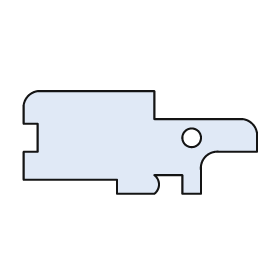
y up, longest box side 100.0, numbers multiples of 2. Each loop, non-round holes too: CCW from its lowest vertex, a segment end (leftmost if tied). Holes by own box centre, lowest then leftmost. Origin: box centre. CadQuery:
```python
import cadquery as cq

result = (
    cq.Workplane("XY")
    .moveTo(-10.0, -22.0)
    .lineTo(6.0, -22.0)
    .threePointArc((8.0, -18.0), (6.0, -14.0))
    .lineTo(18.0, -14.0)
    .lineTo(18.0, -22.0)
    .lineTo(26.0, -22.0)
    .lineTo(26.0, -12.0)
    .threePointArc((28.0, -6.0), (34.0, -4.0))
    .lineTo(50.0, -4.0)
    .lineTo(50.0, 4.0)
    .threePointArc((48.0, 8.0), (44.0, 10.0))
    .lineTo(6.0, 10.0)
    .lineTo(6.0, 22.0)
    .lineTo(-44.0, 22.0)
    .threePointArc((-48.0, 20.0), (-50.0, 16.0))
    .lineTo(-50.0, 8.0)
    .lineTo(-44.0, 8.0)
    .lineTo(-44.0, -4.0)
    .lineTo(-50.0, -4.0)
    .lineTo(-50.0, -16.0)
    .lineTo(-10.0, -16.0)
    .close()
    .moveTo(22.0, 2.0)
    .circle(4.0)
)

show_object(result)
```